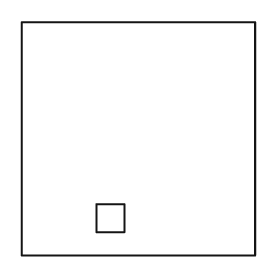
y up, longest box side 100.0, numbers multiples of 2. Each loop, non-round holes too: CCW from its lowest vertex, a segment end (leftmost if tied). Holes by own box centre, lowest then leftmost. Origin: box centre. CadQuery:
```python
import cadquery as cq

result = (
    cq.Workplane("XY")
    .moveTo(-50.0, -50.0)
    .lineTo(50.0, -50.0)
    .lineTo(50.0, 50.0)
    .lineTo(-50.0, 50.0)
    .close()
    .moveTo(-18.0, -40.0)
    .lineTo(-6.0, -40.0)
    .lineTo(-6.0, -28.0)
    .lineTo(-18.0, -28.0)
    .close()
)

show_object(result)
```